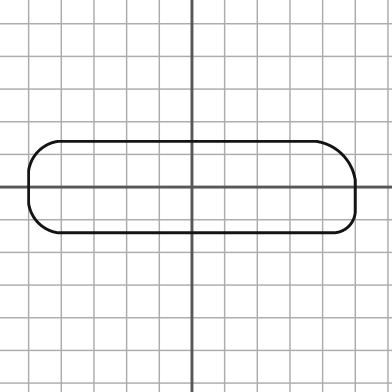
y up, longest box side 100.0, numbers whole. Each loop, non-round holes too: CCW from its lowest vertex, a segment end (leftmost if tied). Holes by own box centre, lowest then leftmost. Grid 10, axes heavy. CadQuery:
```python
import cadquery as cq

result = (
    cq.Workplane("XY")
    .moveTo(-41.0, -14.0)
    .lineTo(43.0, -14.0)
    .threePointArc((48.0, -12.0), (50.0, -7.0))
    .lineTo(50.0, 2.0)
    .threePointArc((46.0, 10.0), (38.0, 14.0))
    .lineTo(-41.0, 14.0)
    .threePointArc((-47.0, 11.0), (-50.0, 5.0))
    .lineTo(-50.0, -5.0)
    .threePointArc((-47.0, -11.0), (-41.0, -14.0))
    .close()
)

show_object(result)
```